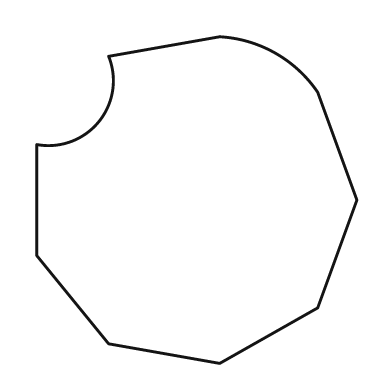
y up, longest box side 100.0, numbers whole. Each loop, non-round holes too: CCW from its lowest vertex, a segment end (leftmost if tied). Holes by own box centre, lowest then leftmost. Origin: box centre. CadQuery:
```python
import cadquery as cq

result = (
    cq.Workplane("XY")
    .moveTo(7.0, -50.0)
    .lineTo(37.0, -33.0)
    .lineTo(49.0, 0.0)
    .lineTo(37.0, 33.0)
    .threePointArc((24.0, 45.0), (7.0, 50.0))
    .lineTo(-27.0, 44.0)
    .threePointArc((-30.0, 24.0), (-49.0, 17.0))
    .lineTo(-49.0, -17.0)
    .lineTo(-27.0, -44.0)
    .close()
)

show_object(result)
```